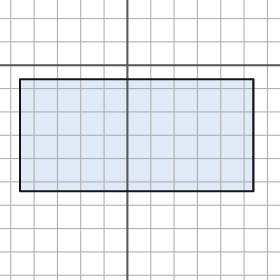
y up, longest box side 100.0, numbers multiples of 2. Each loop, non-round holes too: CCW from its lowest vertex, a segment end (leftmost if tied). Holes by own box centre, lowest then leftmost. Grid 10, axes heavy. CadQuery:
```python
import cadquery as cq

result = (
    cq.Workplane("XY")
    .moveTo(-46.0, -54.0)
    .lineTo(54.0, -54.0)
    .lineTo(54.0, -6.0)
    .lineTo(-46.0, -6.0)
    .close()
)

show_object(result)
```